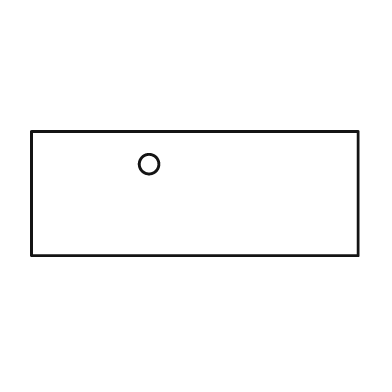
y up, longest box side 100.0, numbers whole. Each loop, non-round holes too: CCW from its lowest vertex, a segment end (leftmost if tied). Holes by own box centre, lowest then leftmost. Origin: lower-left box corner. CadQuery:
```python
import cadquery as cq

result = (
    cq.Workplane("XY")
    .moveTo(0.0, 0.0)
    .lineTo(100.0, 0.0)
    .lineTo(100.0, 38.0)
    .lineTo(0.0, 38.0)
    .close()
    .moveTo(36.0, 28.0)
    .circle(3.0)
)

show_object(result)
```